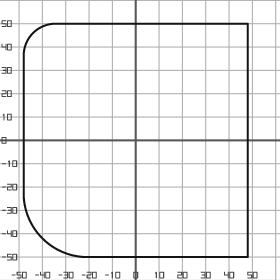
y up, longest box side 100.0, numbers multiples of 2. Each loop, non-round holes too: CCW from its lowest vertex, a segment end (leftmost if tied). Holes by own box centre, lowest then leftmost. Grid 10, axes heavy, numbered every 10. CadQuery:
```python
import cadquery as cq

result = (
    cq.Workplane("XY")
    .moveTo(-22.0, -50.0)
    .lineTo(48.0, -50.0)
    .lineTo(48.0, 50.0)
    .lineTo(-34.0, 50.0)
    .threePointArc((-44.0, 46.0), (-48.0, 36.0))
    .lineTo(-48.0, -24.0)
    .threePointArc((-40.0, -42.0), (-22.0, -50.0))
    .close()
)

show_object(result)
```